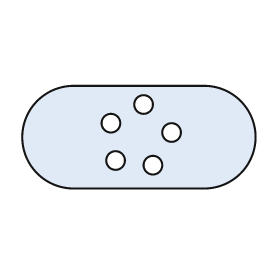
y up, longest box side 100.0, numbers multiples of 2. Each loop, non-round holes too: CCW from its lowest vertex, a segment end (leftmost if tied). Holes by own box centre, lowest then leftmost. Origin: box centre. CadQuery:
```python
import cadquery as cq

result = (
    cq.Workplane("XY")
    .moveTo(-28.0, -22.0)
    .lineTo(28.0, -22.0)
    .threePointArc((50.0, 0.0), (28.0, 22.0))
    .lineTo(-28.0, 22.0)
    .threePointArc((-50.0, 0.0), (-28.0, -22.0))
    .close()
    .moveTo(6.0, -12.0)
    .circle(4.0)
    .moveTo(-10.0, -10.0)
    .circle(4.0)
    .moveTo(14.0, 2.0)
    .circle(4.0)
    .moveTo(-12.0, 6.0)
    .circle(4.0)
    .moveTo(2.0, 14.0)
    .circle(4.0)
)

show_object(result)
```